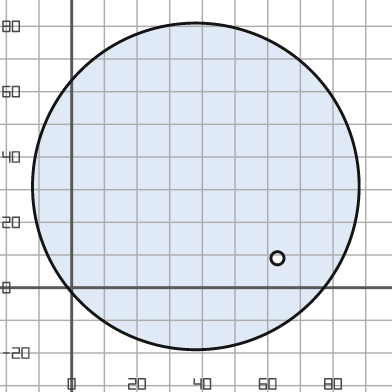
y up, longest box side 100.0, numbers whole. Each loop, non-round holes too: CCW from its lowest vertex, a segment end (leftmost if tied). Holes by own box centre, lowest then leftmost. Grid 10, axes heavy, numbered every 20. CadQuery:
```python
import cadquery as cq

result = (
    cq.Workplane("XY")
    .moveTo(38.0, 31.0)
    .circle(50.0)
    .moveTo(63.0, 9.0)
    .circle(2.0)
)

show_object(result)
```